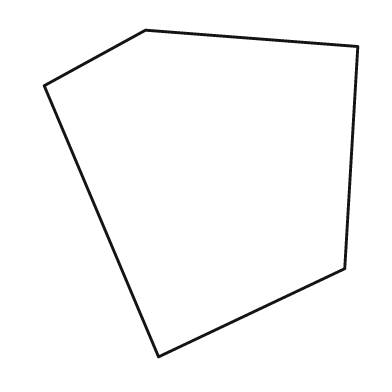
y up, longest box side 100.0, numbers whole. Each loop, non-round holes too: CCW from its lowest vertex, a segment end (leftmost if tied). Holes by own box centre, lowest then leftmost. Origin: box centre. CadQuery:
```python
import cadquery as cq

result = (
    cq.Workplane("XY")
    .moveTo(-13.0, -50.0)
    .lineTo(44.0, -23.0)
    .lineTo(48.0, 45.0)
    .lineTo(-17.0, 50.0)
    .lineTo(-48.0, 33.0)
    .close()
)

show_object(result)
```